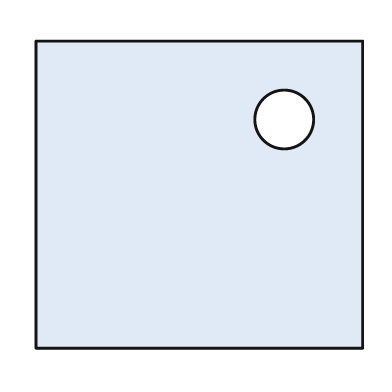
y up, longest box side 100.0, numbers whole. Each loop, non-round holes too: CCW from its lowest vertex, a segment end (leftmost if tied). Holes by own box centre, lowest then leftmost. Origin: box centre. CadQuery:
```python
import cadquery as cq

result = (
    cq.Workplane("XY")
    .moveTo(-50.0, -47.0)
    .lineTo(50.0, -47.0)
    .lineTo(50.0, 47.0)
    .lineTo(-50.0, 47.0)
    .close()
    .moveTo(26.0, 23.0)
    .circle(9.0)
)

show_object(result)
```